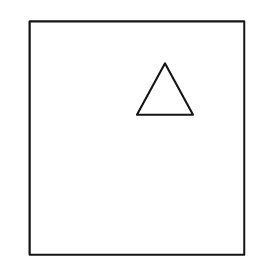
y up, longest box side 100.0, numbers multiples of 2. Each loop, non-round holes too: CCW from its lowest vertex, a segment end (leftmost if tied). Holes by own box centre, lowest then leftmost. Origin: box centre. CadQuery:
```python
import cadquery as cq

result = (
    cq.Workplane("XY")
    .moveTo(-46.0, -50.0)
    .lineTo(46.0, -50.0)
    .lineTo(46.0, 50.0)
    .lineTo(-46.0, 50.0)
    .close()
    .moveTo(0.0, 10.0)
    .lineTo(24.0, 10.0)
    .lineTo(12.0, 32.0)
    .close()
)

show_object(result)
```